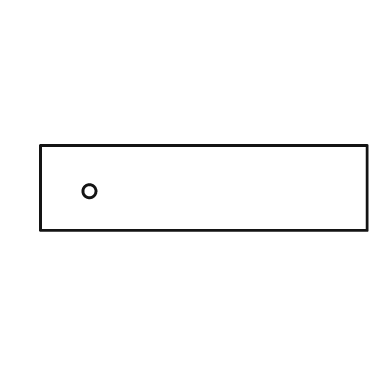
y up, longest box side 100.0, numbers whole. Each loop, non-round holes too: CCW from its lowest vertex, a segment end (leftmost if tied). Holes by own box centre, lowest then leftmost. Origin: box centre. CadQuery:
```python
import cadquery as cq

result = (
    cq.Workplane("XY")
    .moveTo(-50.0, -13.0)
    .lineTo(50.0, -13.0)
    .lineTo(50.0, 13.0)
    .lineTo(-50.0, 13.0)
    .close()
    .moveTo(-35.0, -1.0)
    .circle(2.0)
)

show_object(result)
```